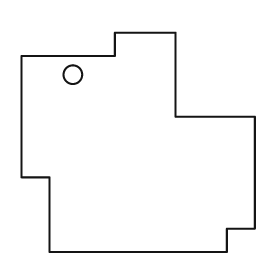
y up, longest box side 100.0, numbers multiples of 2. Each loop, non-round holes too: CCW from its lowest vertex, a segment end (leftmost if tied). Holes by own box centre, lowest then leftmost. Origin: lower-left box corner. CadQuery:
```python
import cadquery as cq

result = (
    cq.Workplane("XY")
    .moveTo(12.0, 0.0)
    .lineTo(88.0, 0.0)
    .lineTo(88.0, 10.0)
    .lineTo(100.0, 10.0)
    .lineTo(100.0, 58.0)
    .lineTo(66.0, 58.0)
    .lineTo(66.0, 94.0)
    .lineTo(40.0, 94.0)
    .lineTo(40.0, 84.0)
    .lineTo(0.0, 84.0)
    .lineTo(0.0, 32.0)
    .lineTo(12.0, 32.0)
    .close()
    .moveTo(22.0, 76.0)
    .circle(4.0)
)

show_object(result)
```